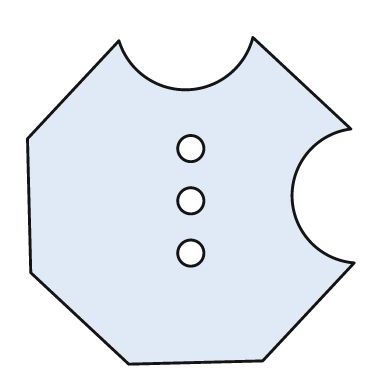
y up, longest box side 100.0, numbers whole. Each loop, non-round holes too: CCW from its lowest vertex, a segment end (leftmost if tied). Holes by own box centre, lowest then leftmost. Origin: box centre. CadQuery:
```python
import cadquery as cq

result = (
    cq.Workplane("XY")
    .moveTo(-19.0, -50.0)
    .lineTo(22.0, -49.0)
    .lineTo(50.0, -19.0)
    .threePointArc((31.0, 1.0), (49.0, 22.0))
    .lineTo(19.0, 50.0)
    .threePointArc((-1.0, 34.0), (-22.0, 49.0))
    .lineTo(-50.0, 19.0)
    .lineTo(-49.0, -22.0)
    .close()
    .moveTo(0.0, -16.0)
    .circle(4.0)
    .moveTo(0.0, 0.0)
    .circle(4.0)
    .moveTo(0.0, 16.0)
    .circle(4.0)
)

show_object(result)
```